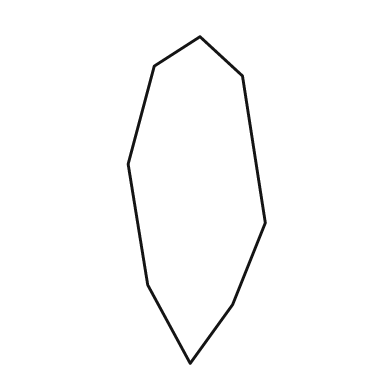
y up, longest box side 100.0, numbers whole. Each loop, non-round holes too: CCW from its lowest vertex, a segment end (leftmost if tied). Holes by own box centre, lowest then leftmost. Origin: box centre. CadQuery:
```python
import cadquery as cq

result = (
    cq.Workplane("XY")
    .moveTo(-2.0, -50.0)
    .lineTo(11.0, -32.0)
    .lineTo(21.0, -7.0)
    .lineTo(14.0, 38.0)
    .lineTo(1.0, 50.0)
    .lineTo(-13.0, 41.0)
    .lineTo(-21.0, 11.0)
    .lineTo(-15.0, -26.0)
    .close()
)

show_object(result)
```